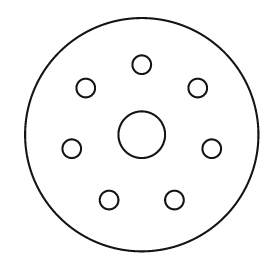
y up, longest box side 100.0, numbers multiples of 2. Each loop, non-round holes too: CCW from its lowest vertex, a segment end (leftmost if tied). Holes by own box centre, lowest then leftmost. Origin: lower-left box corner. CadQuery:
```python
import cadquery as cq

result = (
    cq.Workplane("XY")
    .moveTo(50.0, 50.0)
    .circle(50.0)
    .moveTo(36.0, 22.0)
    .circle(4.0)
    .moveTo(64.0, 22.0)
    .circle(4.0)
    .moveTo(20.0, 44.0)
    .circle(4.0)
    .moveTo(80.0, 44.0)
    .circle(4.0)
    .moveTo(50.0, 50.0)
    .circle(10.0)
    .moveTo(26.0, 70.0)
    .circle(4.0)
    .moveTo(74.0, 70.0)
    .circle(4.0)
    .moveTo(50.0, 80.0)
    .circle(4.0)
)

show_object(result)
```